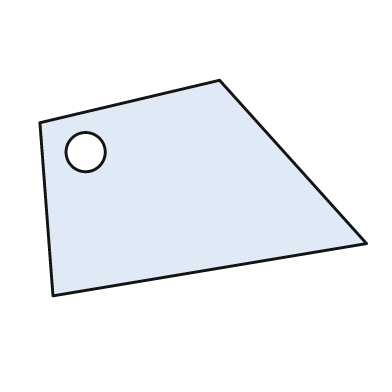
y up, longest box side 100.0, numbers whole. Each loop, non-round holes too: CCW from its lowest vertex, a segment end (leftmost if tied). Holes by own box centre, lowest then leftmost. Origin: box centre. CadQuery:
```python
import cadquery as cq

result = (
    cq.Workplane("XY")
    .moveTo(-46.0, -33.0)
    .lineTo(50.0, -17.0)
    .lineTo(5.0, 33.0)
    .lineTo(-50.0, 20.0)
    .close()
    .moveTo(-36.0, 11.0)
    .circle(6.0)
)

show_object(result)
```